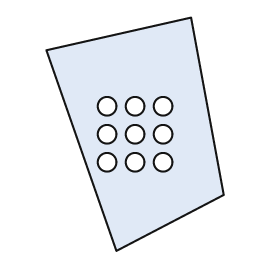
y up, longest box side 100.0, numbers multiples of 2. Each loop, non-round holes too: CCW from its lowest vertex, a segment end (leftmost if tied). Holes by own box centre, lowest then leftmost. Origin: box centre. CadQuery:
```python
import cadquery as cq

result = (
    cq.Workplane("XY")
    .moveTo(-8.0, -50.0)
    .lineTo(38.0, -26.0)
    .lineTo(24.0, 50.0)
    .lineTo(-38.0, 36.0)
    .close()
    .moveTo(-12.0, -12.0)
    .circle(4.0)
    .moveTo(0.0, -12.0)
    .circle(4.0)
    .moveTo(12.0, -12.0)
    .circle(4.0)
    .moveTo(-12.0, 0.0)
    .circle(4.0)
    .moveTo(0.0, 0.0)
    .circle(4.0)
    .moveTo(12.0, 0.0)
    .circle(4.0)
    .moveTo(-12.0, 12.0)
    .circle(4.0)
    .moveTo(0.0, 12.0)
    .circle(4.0)
    .moveTo(12.0, 12.0)
    .circle(4.0)
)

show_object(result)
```